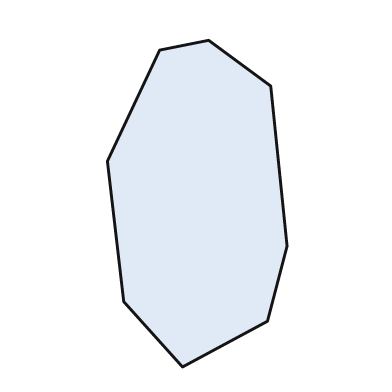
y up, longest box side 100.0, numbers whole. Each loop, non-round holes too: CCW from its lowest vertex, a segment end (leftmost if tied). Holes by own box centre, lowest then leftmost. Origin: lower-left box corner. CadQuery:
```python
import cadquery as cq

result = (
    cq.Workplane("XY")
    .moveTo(23.0, 0.0)
    .lineTo(49.0, 14.0)
    .lineTo(55.0, 37.0)
    .lineTo(50.0, 86.0)
    .lineTo(31.0, 100.0)
    .lineTo(16.0, 97.0)
    .lineTo(0.0, 63.0)
    .lineTo(5.0, 20.0)
    .close()
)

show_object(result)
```